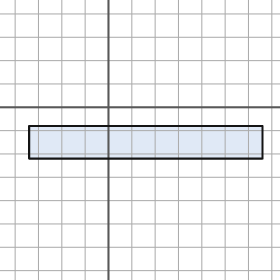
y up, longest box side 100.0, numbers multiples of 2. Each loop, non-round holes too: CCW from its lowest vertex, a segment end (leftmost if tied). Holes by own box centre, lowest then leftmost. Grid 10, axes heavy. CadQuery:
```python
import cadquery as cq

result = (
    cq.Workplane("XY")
    .moveTo(-34.0, -22.0)
    .lineTo(66.0, -22.0)
    .lineTo(66.0, -8.0)
    .lineTo(-34.0, -8.0)
    .close()
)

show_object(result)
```